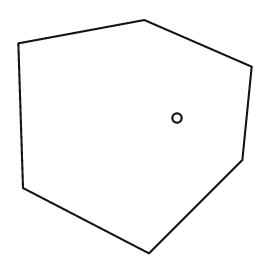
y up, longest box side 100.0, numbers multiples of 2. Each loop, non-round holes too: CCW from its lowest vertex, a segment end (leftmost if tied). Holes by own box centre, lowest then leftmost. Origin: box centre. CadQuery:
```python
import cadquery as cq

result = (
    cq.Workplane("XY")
    .moveTo(6.0, -50.0)
    .lineTo(46.0, -10.0)
    .lineTo(50.0, 30.0)
    .lineTo(4.0, 50.0)
    .lineTo(-50.0, 40.0)
    .lineTo(-48.0, -22.0)
    .close()
    .moveTo(18.0, 8.0)
    .circle(2.0)
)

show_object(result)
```